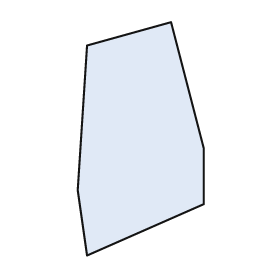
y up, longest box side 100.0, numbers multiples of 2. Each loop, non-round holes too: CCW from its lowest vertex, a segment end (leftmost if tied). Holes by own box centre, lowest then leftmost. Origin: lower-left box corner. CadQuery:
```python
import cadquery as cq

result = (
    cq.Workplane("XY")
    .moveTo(4.0, 0.0)
    .lineTo(54.0, 22.0)
    .lineTo(54.0, 46.0)
    .lineTo(40.0, 100.0)
    .lineTo(4.0, 90.0)
    .lineTo(0.0, 28.0)
    .close()
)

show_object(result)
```